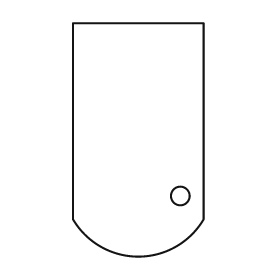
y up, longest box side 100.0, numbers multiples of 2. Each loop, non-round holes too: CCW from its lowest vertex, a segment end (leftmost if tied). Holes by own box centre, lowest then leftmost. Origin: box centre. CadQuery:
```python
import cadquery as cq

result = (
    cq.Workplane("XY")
    .moveTo(-28.0, -34.0)
    .threePointArc((0.0, -50.0), (28.0, -34.0))
    .lineTo(28.0, 50.0)
    .lineTo(-28.0, 50.0)
    .close()
    .moveTo(18.0, -24.0)
    .circle(4.0)
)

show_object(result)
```